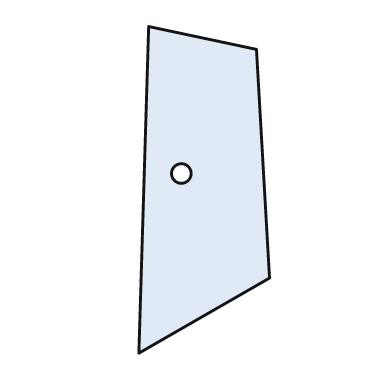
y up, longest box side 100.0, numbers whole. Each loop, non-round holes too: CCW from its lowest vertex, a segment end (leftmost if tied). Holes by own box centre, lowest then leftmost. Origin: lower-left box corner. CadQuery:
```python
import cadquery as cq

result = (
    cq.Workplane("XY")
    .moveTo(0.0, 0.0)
    .lineTo(40.0, 23.0)
    .lineTo(36.0, 93.0)
    .lineTo(3.0, 100.0)
    .close()
    .moveTo(13.0, 55.0)
    .circle(3.0)
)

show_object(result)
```